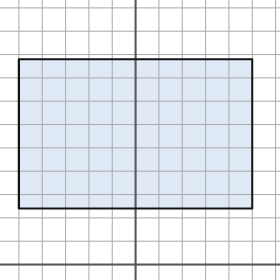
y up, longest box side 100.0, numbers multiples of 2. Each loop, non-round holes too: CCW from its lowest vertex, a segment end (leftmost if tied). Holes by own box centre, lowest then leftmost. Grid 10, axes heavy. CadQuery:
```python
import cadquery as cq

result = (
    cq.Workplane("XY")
    .moveTo(-50.0, 24.0)
    .lineTo(50.0, 24.0)
    .lineTo(50.0, 88.0)
    .lineTo(-50.0, 88.0)
    .close()
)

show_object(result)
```